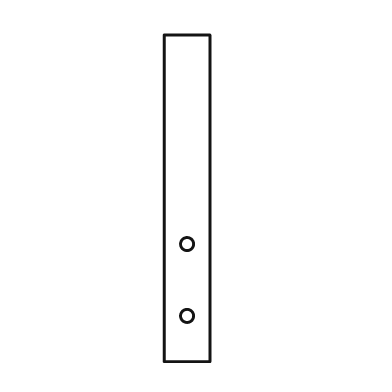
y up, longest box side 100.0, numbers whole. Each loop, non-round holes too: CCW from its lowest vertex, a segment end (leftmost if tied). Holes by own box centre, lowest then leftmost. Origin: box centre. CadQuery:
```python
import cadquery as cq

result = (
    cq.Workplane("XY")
    .moveTo(-7.0, -50.0)
    .lineTo(7.0, -50.0)
    .lineTo(7.0, 50.0)
    .lineTo(-7.0, 50.0)
    .close()
    .moveTo(0.0, -36.0)
    .circle(2.0)
    .moveTo(0.0, -14.0)
    .circle(2.0)
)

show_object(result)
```